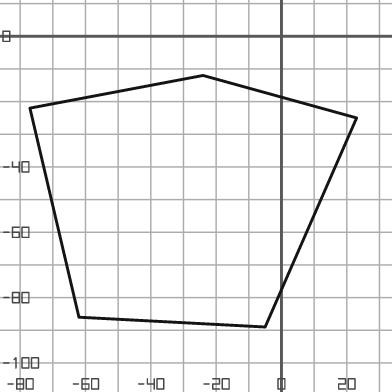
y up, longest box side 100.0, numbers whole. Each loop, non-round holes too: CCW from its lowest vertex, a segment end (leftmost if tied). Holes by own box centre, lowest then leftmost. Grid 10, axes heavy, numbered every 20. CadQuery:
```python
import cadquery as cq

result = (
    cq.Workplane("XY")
    .moveTo(-5.0, -89.0)
    .lineTo(23.0, -25.0)
    .lineTo(-24.0, -12.0)
    .lineTo(-77.0, -22.0)
    .lineTo(-62.0, -86.0)
    .close()
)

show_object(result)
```